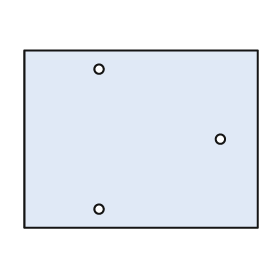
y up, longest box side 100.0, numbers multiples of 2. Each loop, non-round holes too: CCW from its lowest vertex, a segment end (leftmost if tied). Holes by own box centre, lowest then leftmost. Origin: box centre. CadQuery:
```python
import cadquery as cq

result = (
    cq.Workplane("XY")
    .moveTo(-50.0, -38.0)
    .lineTo(50.0, -38.0)
    .lineTo(50.0, 38.0)
    .lineTo(-50.0, 38.0)
    .close()
    .moveTo(-18.0, -30.0)
    .circle(2.0)
    .moveTo(34.0, 0.0)
    .circle(2.0)
    .moveTo(-18.0, 30.0)
    .circle(2.0)
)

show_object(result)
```